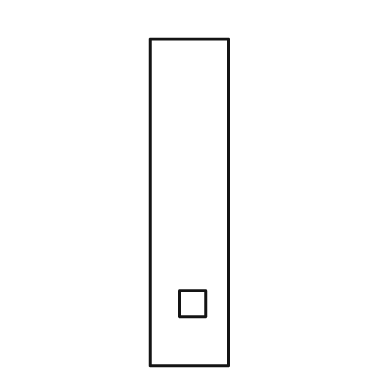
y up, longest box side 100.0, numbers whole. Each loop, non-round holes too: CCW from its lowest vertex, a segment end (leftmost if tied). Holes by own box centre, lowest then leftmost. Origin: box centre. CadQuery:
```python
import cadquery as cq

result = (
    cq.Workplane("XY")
    .moveTo(-12.0, -50.0)
    .lineTo(12.0, -50.0)
    .lineTo(12.0, 50.0)
    .lineTo(-12.0, 50.0)
    .close()
    .moveTo(-3.0, -35.0)
    .lineTo(5.0, -35.0)
    .lineTo(5.0, -27.0)
    .lineTo(-3.0, -27.0)
    .close()
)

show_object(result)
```